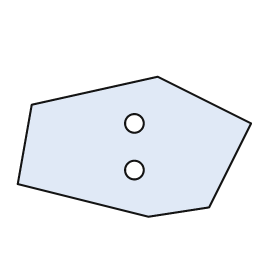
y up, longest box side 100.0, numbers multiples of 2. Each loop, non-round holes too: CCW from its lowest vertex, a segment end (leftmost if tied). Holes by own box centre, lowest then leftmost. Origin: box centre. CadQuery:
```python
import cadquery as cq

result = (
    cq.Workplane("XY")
    .moveTo(6.0, -30.0)
    .lineTo(32.0, -26.0)
    .lineTo(50.0, 10.0)
    .lineTo(10.0, 30.0)
    .lineTo(-44.0, 18.0)
    .lineTo(-50.0, -16.0)
    .close()
    .moveTo(0.0, -10.0)
    .circle(4.0)
    .moveTo(0.0, 10.0)
    .circle(4.0)
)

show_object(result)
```